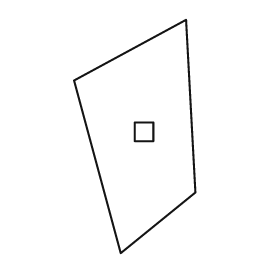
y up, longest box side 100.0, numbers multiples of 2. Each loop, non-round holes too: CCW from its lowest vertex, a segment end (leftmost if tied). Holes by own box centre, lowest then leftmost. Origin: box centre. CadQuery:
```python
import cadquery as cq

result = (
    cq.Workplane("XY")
    .moveTo(-6.0, -50.0)
    .lineTo(26.0, -24.0)
    .lineTo(22.0, 50.0)
    .lineTo(-26.0, 24.0)
    .close()
    .moveTo(0.0, -2.0)
    .lineTo(8.0, -2.0)
    .lineTo(8.0, 6.0)
    .lineTo(0.0, 6.0)
    .close()
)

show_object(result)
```